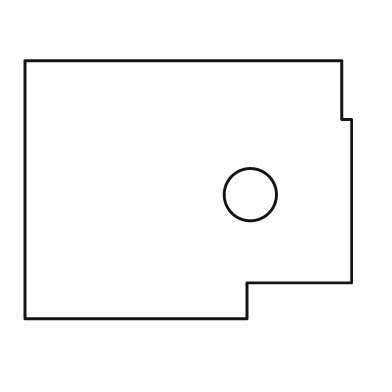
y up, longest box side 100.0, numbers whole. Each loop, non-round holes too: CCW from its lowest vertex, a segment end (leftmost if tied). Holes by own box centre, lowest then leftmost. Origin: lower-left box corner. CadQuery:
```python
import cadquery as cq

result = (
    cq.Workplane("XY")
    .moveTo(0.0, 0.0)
    .lineTo(68.0, 0.0)
    .lineTo(68.0, 11.0)
    .lineTo(100.0, 11.0)
    .lineTo(100.0, 61.0)
    .lineTo(97.0, 61.0)
    .lineTo(97.0, 79.0)
    .lineTo(0.0, 79.0)
    .close()
    .moveTo(69.0, 38.0)
    .circle(8.0)
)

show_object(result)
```